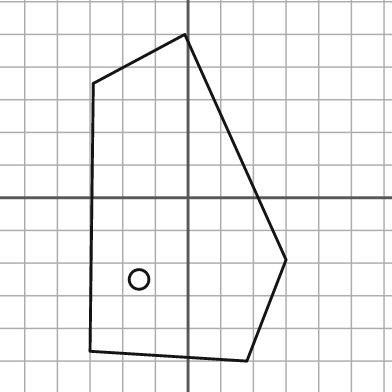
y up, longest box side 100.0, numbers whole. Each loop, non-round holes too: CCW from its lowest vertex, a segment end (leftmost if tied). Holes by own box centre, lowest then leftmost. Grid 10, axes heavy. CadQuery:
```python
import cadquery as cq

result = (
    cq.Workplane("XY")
    .moveTo(18.0, -50.0)
    .lineTo(30.0, -19.0)
    .lineTo(-1.0, 50.0)
    .lineTo(-29.0, 35.0)
    .lineTo(-30.0, -47.0)
    .close()
    .moveTo(-15.0, -25.0)
    .circle(3.0)
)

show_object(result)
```